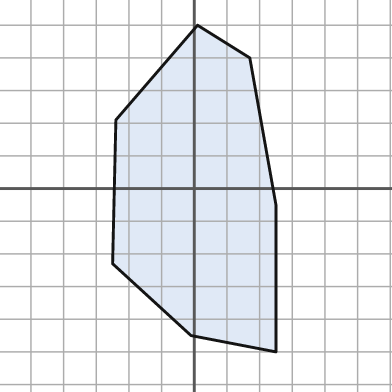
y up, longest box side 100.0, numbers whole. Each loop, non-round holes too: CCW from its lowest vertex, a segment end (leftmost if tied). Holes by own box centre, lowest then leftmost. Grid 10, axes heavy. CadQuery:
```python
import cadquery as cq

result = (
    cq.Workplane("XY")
    .moveTo(25.0, -50.0)
    .lineTo(25.0, -5.0)
    .lineTo(17.0, 40.0)
    .lineTo(1.0, 50.0)
    .lineTo(-24.0, 21.0)
    .lineTo(-25.0, -23.0)
    .lineTo(-1.0, -45.0)
    .close()
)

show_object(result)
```